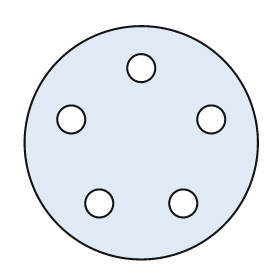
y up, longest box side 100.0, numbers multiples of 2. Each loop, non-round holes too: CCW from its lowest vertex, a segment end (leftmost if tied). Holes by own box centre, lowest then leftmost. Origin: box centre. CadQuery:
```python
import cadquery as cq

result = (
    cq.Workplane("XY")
    .moveTo(0.0, 0.0)
    .circle(50.0)
    .moveTo(-18.0, -26.0)
    .circle(6.0)
    .moveTo(18.0, -26.0)
    .circle(6.0)
    .moveTo(-30.0, 10.0)
    .circle(6.0)
    .moveTo(30.0, 10.0)
    .circle(6.0)
    .moveTo(0.0, 32.0)
    .circle(6.0)
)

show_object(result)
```